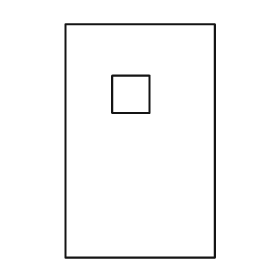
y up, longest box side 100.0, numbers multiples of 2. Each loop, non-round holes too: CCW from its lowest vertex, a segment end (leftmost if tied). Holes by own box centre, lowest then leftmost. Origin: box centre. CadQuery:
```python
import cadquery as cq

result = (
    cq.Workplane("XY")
    .moveTo(-32.0, -50.0)
    .lineTo(32.0, -50.0)
    .lineTo(32.0, 50.0)
    .lineTo(-32.0, 50.0)
    .close()
    .moveTo(-12.0, 12.0)
    .lineTo(4.0, 12.0)
    .lineTo(4.0, 28.0)
    .lineTo(-12.0, 28.0)
    .close()
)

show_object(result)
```